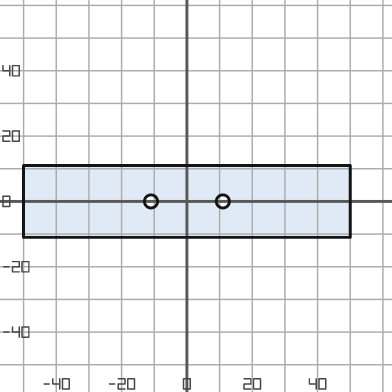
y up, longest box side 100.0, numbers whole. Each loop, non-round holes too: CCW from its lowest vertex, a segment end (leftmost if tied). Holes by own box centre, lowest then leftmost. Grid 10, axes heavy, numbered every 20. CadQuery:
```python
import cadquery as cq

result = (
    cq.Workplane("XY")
    .moveTo(-50.0, -11.0)
    .lineTo(50.0, -11.0)
    .lineTo(50.0, 11.0)
    .lineTo(-50.0, 11.0)
    .close()
    .moveTo(-11.0, 0.0)
    .circle(2.0)
    .moveTo(11.0, 0.0)
    .circle(2.0)
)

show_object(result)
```